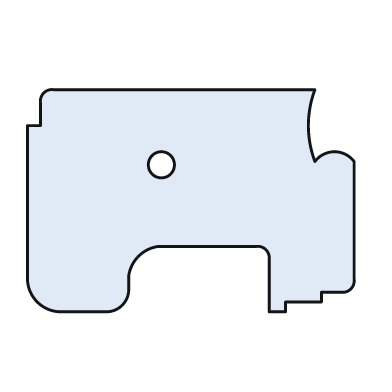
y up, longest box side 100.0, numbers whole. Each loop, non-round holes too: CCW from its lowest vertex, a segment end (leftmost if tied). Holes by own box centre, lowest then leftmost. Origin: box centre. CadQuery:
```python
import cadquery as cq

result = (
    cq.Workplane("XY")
    .moveTo(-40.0, -34.0)
    .lineTo(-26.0, -34.0)
    .threePointArc((-21.0, -32.0), (-19.0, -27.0))
    .lineTo(-19.0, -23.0)
    .threePointArc((-16.0, -17.0), (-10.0, -14.0))
    .lineTo(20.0, -14.0)
    .threePointArc((23.0, -15.0), (24.0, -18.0))
    .lineTo(24.0, -34.0)
    .lineTo(29.0, -34.0)
    .lineTo(29.0, -31.0)
    .lineTo(40.0, -31.0)
    .lineTo(40.0, -28.0)
    .lineTo(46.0, -28.0)
    .threePointArc((49.0, -27.0), (50.0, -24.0))
    .lineTo(50.0, 12.0)
    .threePointArc((44.0, 15.0), (38.0, 12.0))
    .threePointArc((36.0, 23.0), (38.0, 34.0))
    .lineTo(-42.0, 34.0)
    .threePointArc((-45.0, 33.0), (-46.0, 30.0))
    .lineTo(-46.0, 23.0)
    .lineTo(-50.0, 23.0)
    .lineTo(-50.0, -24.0)
    .threePointArc((-47.0, -31.0), (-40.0, -34.0))
    .close()
    .moveTo(-9.0, 11.0)
    .circle(4.0)
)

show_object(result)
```